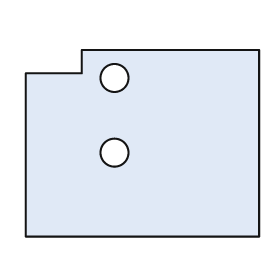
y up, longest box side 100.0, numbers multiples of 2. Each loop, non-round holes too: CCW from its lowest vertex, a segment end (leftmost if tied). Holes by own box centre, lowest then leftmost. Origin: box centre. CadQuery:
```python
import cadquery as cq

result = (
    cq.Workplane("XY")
    .moveTo(-50.0, -40.0)
    .lineTo(50.0, -40.0)
    .lineTo(50.0, 40.0)
    .lineTo(-26.0, 40.0)
    .lineTo(-26.0, 30.0)
    .lineTo(-50.0, 30.0)
    .close()
    .moveTo(-12.0, -4.0)
    .circle(6.0)
    .moveTo(-12.0, 28.0)
    .circle(6.0)
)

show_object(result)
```